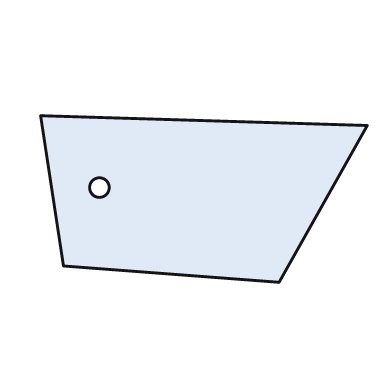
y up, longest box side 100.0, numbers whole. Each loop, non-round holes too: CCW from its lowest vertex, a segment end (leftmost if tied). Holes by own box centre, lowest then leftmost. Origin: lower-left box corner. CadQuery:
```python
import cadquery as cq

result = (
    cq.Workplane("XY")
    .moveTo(73.0, 0.0)
    .lineTo(100.0, 48.0)
    .lineTo(0.0, 51.0)
    .lineTo(7.0, 5.0)
    .close()
    .moveTo(18.0, 29.0)
    .circle(3.0)
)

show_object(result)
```